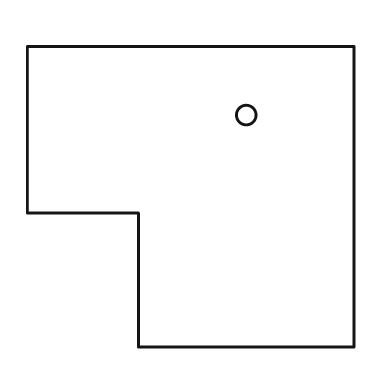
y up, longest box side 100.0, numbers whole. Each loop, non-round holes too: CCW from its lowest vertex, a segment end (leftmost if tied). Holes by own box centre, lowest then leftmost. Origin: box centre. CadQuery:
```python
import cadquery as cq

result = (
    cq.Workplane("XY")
    .moveTo(-16.0, -46.0)
    .lineTo(50.0, -46.0)
    .lineTo(50.0, 46.0)
    .lineTo(-50.0, 46.0)
    .lineTo(-50.0, -5.0)
    .lineTo(-16.0, -5.0)
    .close()
    .moveTo(17.0, 25.0)
    .circle(3.0)
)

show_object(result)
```